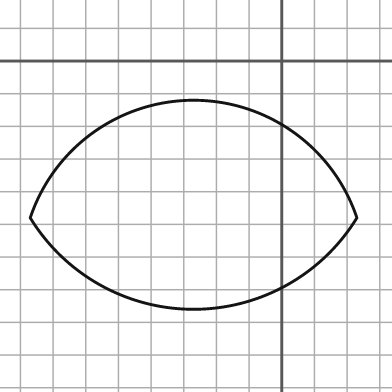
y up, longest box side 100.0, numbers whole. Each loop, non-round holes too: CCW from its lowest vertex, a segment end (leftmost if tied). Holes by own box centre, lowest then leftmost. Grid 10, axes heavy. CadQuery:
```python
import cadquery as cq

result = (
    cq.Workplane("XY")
    .moveTo(-77.0, -48.0)
    .threePointArc((-27.0, -76.0), (23.0, -48.0))
    .threePointArc((-27.0, -12.0), (-77.0, -48.0))
    .close()
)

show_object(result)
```